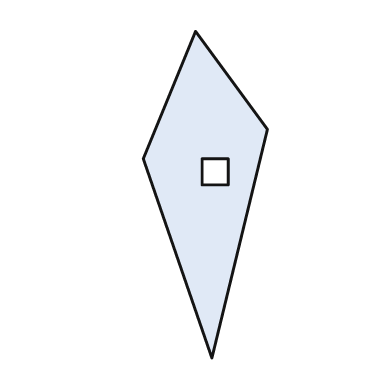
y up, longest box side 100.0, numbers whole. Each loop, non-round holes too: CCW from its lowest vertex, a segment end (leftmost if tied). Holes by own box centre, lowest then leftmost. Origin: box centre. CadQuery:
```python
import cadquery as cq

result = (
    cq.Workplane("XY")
    .moveTo(2.0, -50.0)
    .lineTo(19.0, 20.0)
    .lineTo(-3.0, 50.0)
    .lineTo(-19.0, 11.0)
    .close()
    .moveTo(-1.0, 3.0)
    .lineTo(7.0, 3.0)
    .lineTo(7.0, 11.0)
    .lineTo(-1.0, 11.0)
    .close()
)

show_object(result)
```